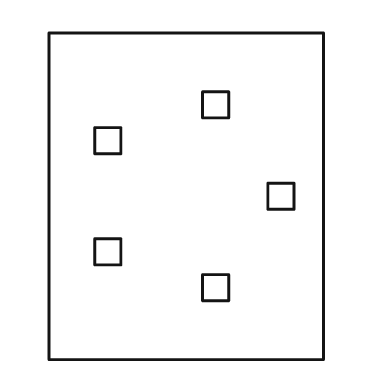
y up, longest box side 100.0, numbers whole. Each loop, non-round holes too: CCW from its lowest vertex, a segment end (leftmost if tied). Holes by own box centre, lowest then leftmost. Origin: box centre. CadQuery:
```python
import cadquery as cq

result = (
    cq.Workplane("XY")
    .moveTo(-42.0, -50.0)
    .lineTo(42.0, -50.0)
    .lineTo(42.0, 50.0)
    .lineTo(-42.0, 50.0)
    .close()
    .moveTo(5.0, -32.0)
    .lineTo(13.0, -32.0)
    .lineTo(13.0, -24.0)
    .lineTo(5.0, -24.0)
    .close()
    .moveTo(-28.0, -21.0)
    .lineTo(-20.0, -21.0)
    .lineTo(-20.0, -13.0)
    .lineTo(-28.0, -13.0)
    .close()
    .moveTo(25.0, -4.0)
    .lineTo(33.0, -4.0)
    .lineTo(33.0, 4.0)
    .lineTo(25.0, 4.0)
    .close()
    .moveTo(-28.0, 13.0)
    .lineTo(-20.0, 13.0)
    .lineTo(-20.0, 21.0)
    .lineTo(-28.0, 21.0)
    .close()
    .moveTo(5.0, 24.0)
    .lineTo(13.0, 24.0)
    .lineTo(13.0, 32.0)
    .lineTo(5.0, 32.0)
    .close()
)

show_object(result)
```